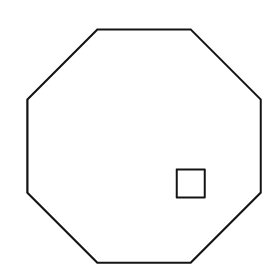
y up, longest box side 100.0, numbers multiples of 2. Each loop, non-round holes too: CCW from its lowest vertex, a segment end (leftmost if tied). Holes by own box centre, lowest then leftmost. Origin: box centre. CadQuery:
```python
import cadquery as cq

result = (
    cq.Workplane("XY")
    .moveTo(-20.0, -50.0)
    .lineTo(20.0, -50.0)
    .lineTo(50.0, -20.0)
    .lineTo(50.0, 20.0)
    .lineTo(20.0, 50.0)
    .lineTo(-20.0, 50.0)
    .lineTo(-50.0, 20.0)
    .lineTo(-50.0, -20.0)
    .close()
    .moveTo(14.0, -22.0)
    .lineTo(26.0, -22.0)
    .lineTo(26.0, -10.0)
    .lineTo(14.0, -10.0)
    .close()
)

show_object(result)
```